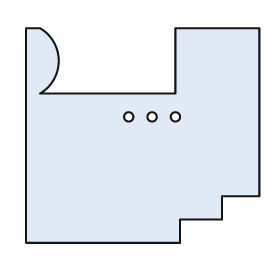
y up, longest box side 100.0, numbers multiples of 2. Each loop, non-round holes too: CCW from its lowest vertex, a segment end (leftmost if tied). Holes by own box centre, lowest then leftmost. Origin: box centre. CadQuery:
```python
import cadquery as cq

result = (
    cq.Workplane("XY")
    .moveTo(-50.0, -46.0)
    .lineTo(16.0, -46.0)
    .lineTo(16.0, -36.0)
    .lineTo(34.0, -36.0)
    .lineTo(34.0, -26.0)
    .lineTo(50.0, -26.0)
    .lineTo(50.0, 46.0)
    .lineTo(14.0, 46.0)
    .lineTo(14.0, 18.0)
    .lineTo(-44.0, 18.0)
    .threePointArc((-36.0, 32.0), (-44.0, 46.0))
    .lineTo(-50.0, 46.0)
    .close()
    .moveTo(-6.0, 8.0)
    .circle(2.0)
    .moveTo(4.0, 8.0)
    .circle(2.0)
    .moveTo(14.0, 8.0)
    .circle(2.0)
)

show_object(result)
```